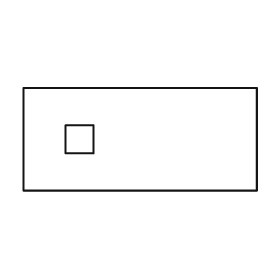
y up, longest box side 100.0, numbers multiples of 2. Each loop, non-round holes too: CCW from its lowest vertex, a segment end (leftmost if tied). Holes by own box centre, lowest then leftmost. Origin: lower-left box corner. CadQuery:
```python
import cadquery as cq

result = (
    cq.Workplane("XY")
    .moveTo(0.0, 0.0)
    .lineTo(100.0, 0.0)
    .lineTo(100.0, 44.0)
    .lineTo(0.0, 44.0)
    .close()
    .moveTo(18.0, 16.0)
    .lineTo(30.0, 16.0)
    .lineTo(30.0, 28.0)
    .lineTo(18.0, 28.0)
    .close()
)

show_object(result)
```